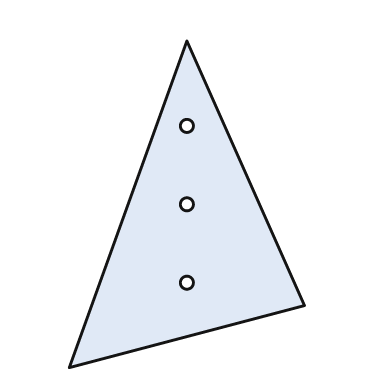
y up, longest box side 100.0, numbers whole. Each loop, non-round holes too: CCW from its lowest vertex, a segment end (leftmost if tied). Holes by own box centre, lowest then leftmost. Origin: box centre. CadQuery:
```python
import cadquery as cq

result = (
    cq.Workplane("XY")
    .moveTo(-36.0, -50.0)
    .lineTo(36.0, -31.0)
    .lineTo(0.0, 50.0)
    .close()
    .moveTo(0.0, -24.0)
    .circle(2.0)
    .moveTo(0.0, 0.0)
    .circle(2.0)
    .moveTo(0.0, 24.0)
    .circle(2.0)
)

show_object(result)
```